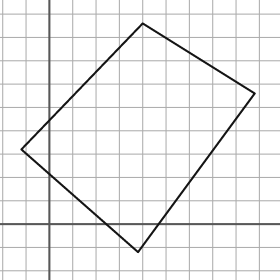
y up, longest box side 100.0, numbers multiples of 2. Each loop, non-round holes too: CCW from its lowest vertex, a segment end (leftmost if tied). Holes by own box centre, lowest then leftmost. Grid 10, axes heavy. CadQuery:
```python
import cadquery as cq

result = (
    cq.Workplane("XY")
    .moveTo(38.0, -12.0)
    .lineTo(88.0, 56.0)
    .lineTo(40.0, 86.0)
    .lineTo(-12.0, 32.0)
    .close()
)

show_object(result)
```